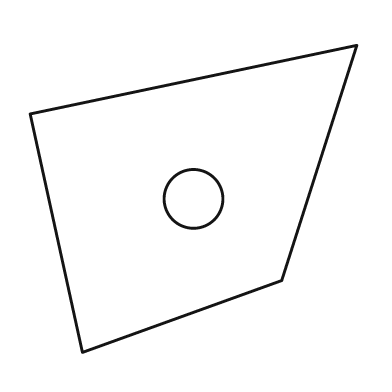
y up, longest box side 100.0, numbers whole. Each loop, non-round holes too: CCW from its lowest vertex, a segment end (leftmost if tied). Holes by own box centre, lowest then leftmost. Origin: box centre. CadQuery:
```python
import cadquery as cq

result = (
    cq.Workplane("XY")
    .moveTo(-34.0, -47.0)
    .lineTo(27.0, -25.0)
    .lineTo(50.0, 47.0)
    .lineTo(-50.0, 26.0)
    .close()
    .moveTo(0.0, 0.0)
    .circle(9.0)
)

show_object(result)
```